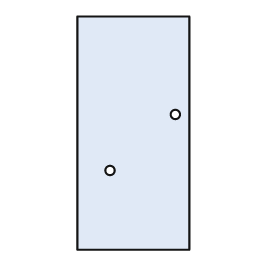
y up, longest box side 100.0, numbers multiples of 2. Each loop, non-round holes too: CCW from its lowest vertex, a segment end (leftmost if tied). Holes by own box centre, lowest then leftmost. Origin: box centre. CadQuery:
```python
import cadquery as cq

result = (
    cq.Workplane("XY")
    .moveTo(-24.0, -50.0)
    .lineTo(24.0, -50.0)
    .lineTo(24.0, 50.0)
    .lineTo(-24.0, 50.0)
    .close()
    .moveTo(-10.0, -16.0)
    .circle(2.0)
    .moveTo(18.0, 8.0)
    .circle(2.0)
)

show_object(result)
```